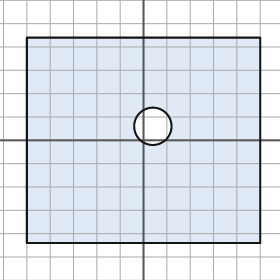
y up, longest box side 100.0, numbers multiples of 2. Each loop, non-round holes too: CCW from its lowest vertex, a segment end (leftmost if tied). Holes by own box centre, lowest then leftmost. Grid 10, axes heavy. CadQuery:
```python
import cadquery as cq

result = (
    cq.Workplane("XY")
    .moveTo(-50.0, -44.0)
    .lineTo(50.0, -44.0)
    .lineTo(50.0, 44.0)
    .lineTo(-50.0, 44.0)
    .close()
    .moveTo(4.0, 6.0)
    .circle(8.0)
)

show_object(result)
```